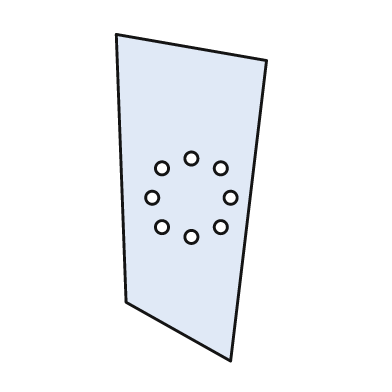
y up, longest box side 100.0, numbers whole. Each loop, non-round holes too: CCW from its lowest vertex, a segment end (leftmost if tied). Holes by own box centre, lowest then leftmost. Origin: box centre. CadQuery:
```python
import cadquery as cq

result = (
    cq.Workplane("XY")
    .moveTo(12.0, -50.0)
    .lineTo(23.0, 42.0)
    .lineTo(-23.0, 50.0)
    .lineTo(-20.0, -32.0)
    .close()
    .moveTo(0.0, -12.0)
    .circle(2.0)
    .moveTo(-9.0, -9.0)
    .circle(2.0)
    .moveTo(9.0, -9.0)
    .circle(2.0)
    .moveTo(-12.0, 0.0)
    .circle(2.0)
    .moveTo(12.0, 0.0)
    .circle(2.0)
    .moveTo(-9.0, 9.0)
    .circle(2.0)
    .moveTo(9.0, 9.0)
    .circle(2.0)
    .moveTo(0.0, 12.0)
    .circle(2.0)
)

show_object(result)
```